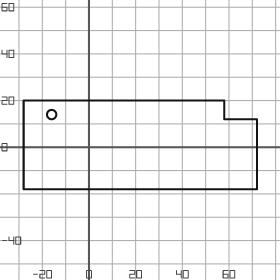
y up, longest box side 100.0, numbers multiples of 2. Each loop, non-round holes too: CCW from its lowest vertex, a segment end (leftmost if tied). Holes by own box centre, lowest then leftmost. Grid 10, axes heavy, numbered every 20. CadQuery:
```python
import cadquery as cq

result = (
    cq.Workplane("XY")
    .moveTo(-28.0, -18.0)
    .lineTo(72.0, -18.0)
    .lineTo(72.0, 12.0)
    .lineTo(58.0, 12.0)
    .lineTo(58.0, 20.0)
    .lineTo(-28.0, 20.0)
    .close()
    .moveTo(-16.0, 14.0)
    .circle(2.0)
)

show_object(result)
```